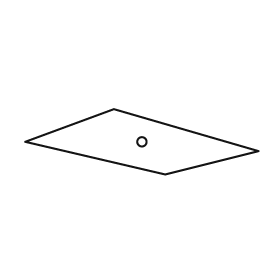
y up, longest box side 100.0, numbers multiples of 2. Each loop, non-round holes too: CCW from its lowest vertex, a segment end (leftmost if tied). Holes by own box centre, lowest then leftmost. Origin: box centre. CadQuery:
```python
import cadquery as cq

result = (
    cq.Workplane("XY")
    .moveTo(10.0, -14.0)
    .lineTo(50.0, -4.0)
    .lineTo(-12.0, 14.0)
    .lineTo(-50.0, 0.0)
    .close()
    .moveTo(0.0, 0.0)
    .circle(2.0)
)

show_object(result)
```